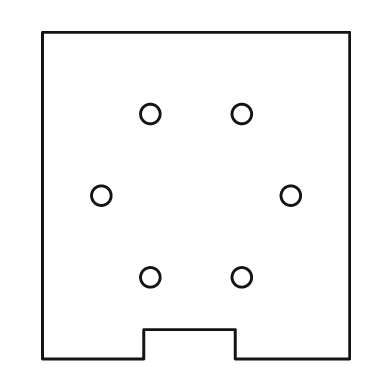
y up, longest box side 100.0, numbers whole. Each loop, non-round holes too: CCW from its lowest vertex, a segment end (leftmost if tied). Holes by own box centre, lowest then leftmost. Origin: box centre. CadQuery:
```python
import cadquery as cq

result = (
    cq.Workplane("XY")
    .moveTo(-47.0, -50.0)
    .lineTo(-16.0, -50.0)
    .lineTo(-16.0, -41.0)
    .lineTo(12.0, -41.0)
    .lineTo(12.0, -50.0)
    .lineTo(47.0, -50.0)
    .lineTo(47.0, 50.0)
    .lineTo(-47.0, 50.0)
    .close()
    .moveTo(-14.0, -25.0)
    .circle(3.0)
    .moveTo(14.0, -25.0)
    .circle(3.0)
    .moveTo(-29.0, 0.0)
    .circle(3.0)
    .moveTo(29.0, 0.0)
    .circle(3.0)
    .moveTo(-14.0, 25.0)
    .circle(3.0)
    .moveTo(14.0, 25.0)
    .circle(3.0)
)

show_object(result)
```